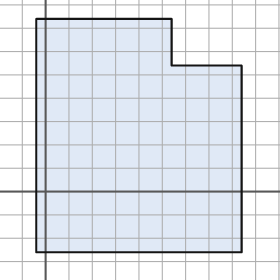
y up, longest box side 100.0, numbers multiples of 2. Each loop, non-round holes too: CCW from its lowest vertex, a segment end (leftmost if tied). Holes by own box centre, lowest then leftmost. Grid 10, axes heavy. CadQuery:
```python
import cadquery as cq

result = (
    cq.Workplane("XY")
    .moveTo(-4.0, -26.0)
    .lineTo(84.0, -26.0)
    .lineTo(84.0, 54.0)
    .lineTo(54.0, 54.0)
    .lineTo(54.0, 74.0)
    .lineTo(-4.0, 74.0)
    .close()
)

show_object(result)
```